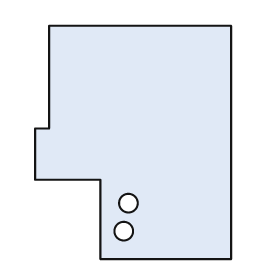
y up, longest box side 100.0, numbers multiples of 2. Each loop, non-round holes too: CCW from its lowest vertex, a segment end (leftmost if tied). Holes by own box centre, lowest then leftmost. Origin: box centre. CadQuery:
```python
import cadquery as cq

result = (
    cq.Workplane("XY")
    .moveTo(-14.0, -50.0)
    .lineTo(42.0, -50.0)
    .lineTo(42.0, 50.0)
    .lineTo(-36.0, 50.0)
    .lineTo(-36.0, 6.0)
    .lineTo(-42.0, 6.0)
    .lineTo(-42.0, -16.0)
    .lineTo(-14.0, -16.0)
    .close()
    .moveTo(-4.0, -38.0)
    .circle(4.0)
    .moveTo(-2.0, -26.0)
    .circle(4.0)
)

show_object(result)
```